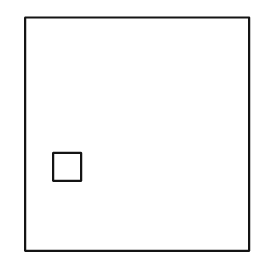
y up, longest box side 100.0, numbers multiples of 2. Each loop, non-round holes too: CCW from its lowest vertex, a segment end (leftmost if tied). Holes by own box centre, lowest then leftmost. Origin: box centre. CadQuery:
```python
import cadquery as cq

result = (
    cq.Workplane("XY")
    .moveTo(-48.0, -50.0)
    .lineTo(48.0, -50.0)
    .lineTo(48.0, 50.0)
    .lineTo(-48.0, 50.0)
    .close()
    .moveTo(-36.0, -20.0)
    .lineTo(-24.0, -20.0)
    .lineTo(-24.0, -8.0)
    .lineTo(-36.0, -8.0)
    .close()
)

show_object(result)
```